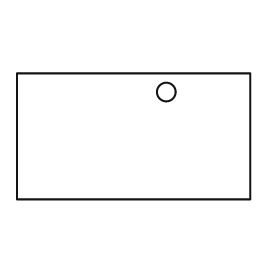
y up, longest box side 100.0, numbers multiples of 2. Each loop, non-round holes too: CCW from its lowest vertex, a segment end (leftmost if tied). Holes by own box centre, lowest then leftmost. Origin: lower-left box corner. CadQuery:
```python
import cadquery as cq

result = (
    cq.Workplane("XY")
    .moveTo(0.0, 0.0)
    .lineTo(100.0, 0.0)
    .lineTo(100.0, 54.0)
    .lineTo(0.0, 54.0)
    .close()
    .moveTo(64.0, 46.0)
    .circle(4.0)
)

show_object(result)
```